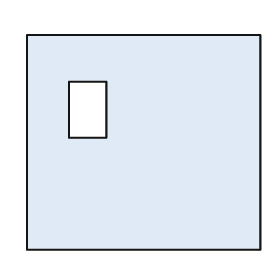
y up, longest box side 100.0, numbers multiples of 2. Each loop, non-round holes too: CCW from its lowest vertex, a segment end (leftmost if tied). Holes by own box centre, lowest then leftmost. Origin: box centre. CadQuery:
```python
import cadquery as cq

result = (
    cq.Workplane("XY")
    .moveTo(-50.0, -46.0)
    .lineTo(50.0, -46.0)
    .lineTo(50.0, 46.0)
    .lineTo(-50.0, 46.0)
    .close()
    .moveTo(-32.0, 2.0)
    .lineTo(-16.0, 2.0)
    .lineTo(-16.0, 26.0)
    .lineTo(-32.0, 26.0)
    .close()
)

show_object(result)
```